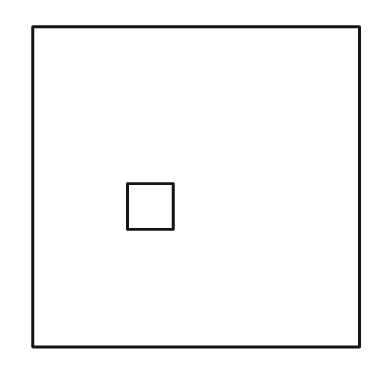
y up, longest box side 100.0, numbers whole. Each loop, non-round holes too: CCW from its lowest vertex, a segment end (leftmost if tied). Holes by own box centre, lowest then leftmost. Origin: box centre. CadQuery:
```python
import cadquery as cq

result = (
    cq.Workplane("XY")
    .moveTo(-50.0, -49.0)
    .lineTo(50.0, -49.0)
    .lineTo(50.0, 49.0)
    .lineTo(-50.0, 49.0)
    .close()
    .moveTo(-21.0, -13.0)
    .lineTo(-7.0, -13.0)
    .lineTo(-7.0, 1.0)
    .lineTo(-21.0, 1.0)
    .close()
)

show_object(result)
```